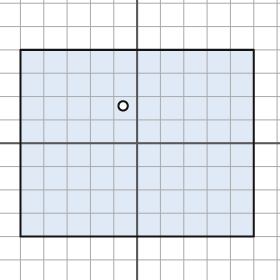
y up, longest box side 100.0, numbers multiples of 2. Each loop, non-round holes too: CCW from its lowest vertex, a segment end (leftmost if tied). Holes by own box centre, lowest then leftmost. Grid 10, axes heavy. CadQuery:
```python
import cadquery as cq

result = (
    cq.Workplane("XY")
    .moveTo(-50.0, -40.0)
    .lineTo(50.0, -40.0)
    .lineTo(50.0, 40.0)
    .lineTo(-50.0, 40.0)
    .close()
    .moveTo(-6.0, 16.0)
    .circle(2.0)
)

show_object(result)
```